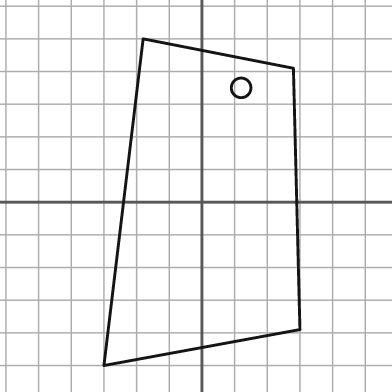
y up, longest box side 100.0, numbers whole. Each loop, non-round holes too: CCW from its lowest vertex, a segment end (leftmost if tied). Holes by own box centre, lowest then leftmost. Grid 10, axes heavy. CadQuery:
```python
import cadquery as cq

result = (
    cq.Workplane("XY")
    .moveTo(-30.0, -50.0)
    .lineTo(30.0, -39.0)
    .lineTo(28.0, 41.0)
    .lineTo(-18.0, 50.0)
    .close()
    .moveTo(12.0, 35.0)
    .circle(3.0)
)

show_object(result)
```